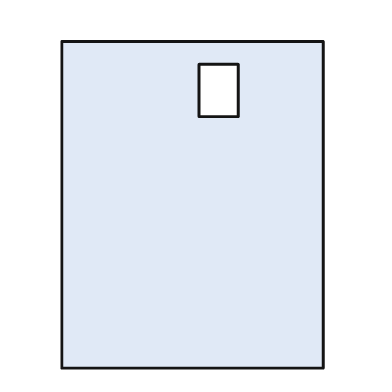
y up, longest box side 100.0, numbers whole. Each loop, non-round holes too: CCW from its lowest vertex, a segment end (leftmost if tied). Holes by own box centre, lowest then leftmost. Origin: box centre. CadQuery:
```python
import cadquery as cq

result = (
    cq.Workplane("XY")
    .moveTo(-40.0, -50.0)
    .lineTo(40.0, -50.0)
    .lineTo(40.0, 50.0)
    .lineTo(-40.0, 50.0)
    .close()
    .moveTo(2.0, 27.0)
    .lineTo(14.0, 27.0)
    .lineTo(14.0, 43.0)
    .lineTo(2.0, 43.0)
    .close()
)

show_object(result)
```